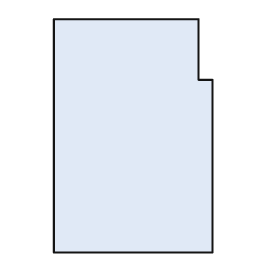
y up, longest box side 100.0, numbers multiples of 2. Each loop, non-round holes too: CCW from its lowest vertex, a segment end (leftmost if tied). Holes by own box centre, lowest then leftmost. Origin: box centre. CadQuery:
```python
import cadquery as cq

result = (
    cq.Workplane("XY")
    .moveTo(-34.0, -50.0)
    .lineTo(34.0, -50.0)
    .lineTo(34.0, 24.0)
    .lineTo(28.0, 24.0)
    .lineTo(28.0, 50.0)
    .lineTo(-34.0, 50.0)
    .close()
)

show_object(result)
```